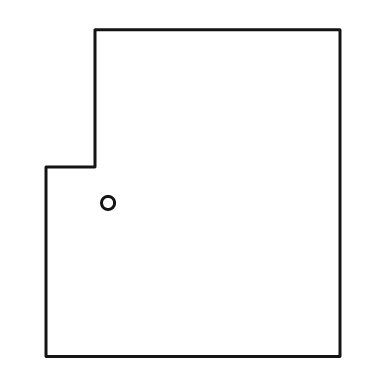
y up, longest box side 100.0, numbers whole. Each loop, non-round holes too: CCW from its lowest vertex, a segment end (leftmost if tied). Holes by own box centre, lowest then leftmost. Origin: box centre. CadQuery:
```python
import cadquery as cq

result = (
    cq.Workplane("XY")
    .moveTo(-45.0, -50.0)
    .lineTo(45.0, -50.0)
    .lineTo(45.0, 50.0)
    .lineTo(-30.0, 50.0)
    .lineTo(-30.0, 8.0)
    .lineTo(-45.0, 8.0)
    .close()
    .moveTo(-26.0, -3.0)
    .circle(2.0)
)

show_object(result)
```